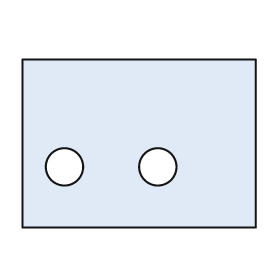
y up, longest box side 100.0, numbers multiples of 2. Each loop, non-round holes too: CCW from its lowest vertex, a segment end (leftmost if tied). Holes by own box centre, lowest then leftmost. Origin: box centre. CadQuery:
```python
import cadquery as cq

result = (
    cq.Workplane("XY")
    .moveTo(-50.0, -36.0)
    .lineTo(50.0, -36.0)
    .lineTo(50.0, 36.0)
    .lineTo(-50.0, 36.0)
    .close()
    .moveTo(-32.0, -10.0)
    .circle(8.0)
    .moveTo(8.0, -10.0)
    .circle(8.0)
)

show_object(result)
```